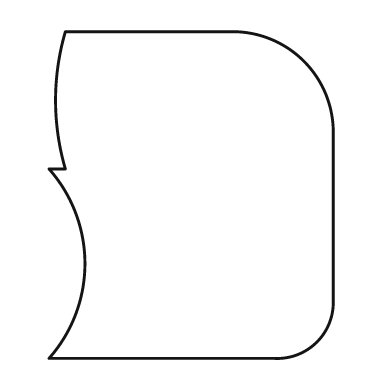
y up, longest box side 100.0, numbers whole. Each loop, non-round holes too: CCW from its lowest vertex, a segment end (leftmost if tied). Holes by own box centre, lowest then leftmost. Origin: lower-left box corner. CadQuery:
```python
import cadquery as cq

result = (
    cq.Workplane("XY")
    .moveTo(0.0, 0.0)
    .lineTo(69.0, 0.0)
    .threePointArc((82.0, 5.0), (87.0, 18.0))
    .lineTo(87.0, 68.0)
    .threePointArc((78.0, 91.0), (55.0, 100.0))
    .lineTo(5.0, 100.0)
    .threePointArc((2.0, 79.0), (5.0, 58.0))
    .lineTo(0.0, 58.0)
    .threePointArc((11.0, 29.0), (0.0, 0.0))
    .close()
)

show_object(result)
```